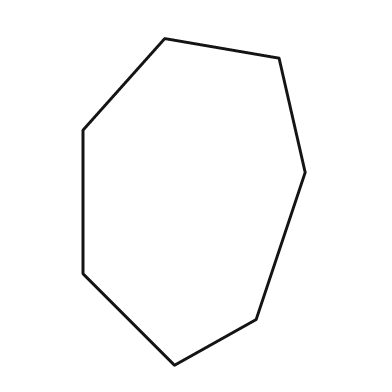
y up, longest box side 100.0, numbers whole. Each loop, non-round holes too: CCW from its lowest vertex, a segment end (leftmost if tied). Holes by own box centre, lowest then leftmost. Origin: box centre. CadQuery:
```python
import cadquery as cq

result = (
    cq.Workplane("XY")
    .moveTo(-6.0, -50.0)
    .lineTo(19.0, -36.0)
    .lineTo(34.0, 9.0)
    .lineTo(26.0, 44.0)
    .lineTo(-9.0, 50.0)
    .lineTo(-34.0, 22.0)
    .lineTo(-34.0, -22.0)
    .close()
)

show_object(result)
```